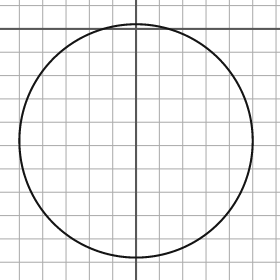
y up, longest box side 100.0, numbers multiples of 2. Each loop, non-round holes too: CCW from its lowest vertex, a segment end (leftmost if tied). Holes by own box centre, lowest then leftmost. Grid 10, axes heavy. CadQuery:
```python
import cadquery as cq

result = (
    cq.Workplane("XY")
    .moveTo(0.0, -48.0)
    .circle(50.0)
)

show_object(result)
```